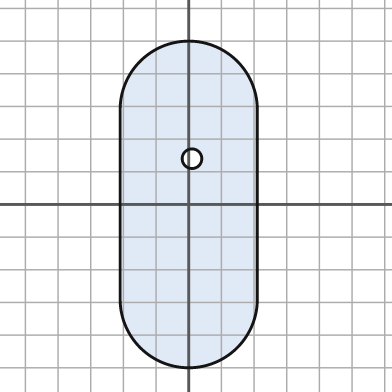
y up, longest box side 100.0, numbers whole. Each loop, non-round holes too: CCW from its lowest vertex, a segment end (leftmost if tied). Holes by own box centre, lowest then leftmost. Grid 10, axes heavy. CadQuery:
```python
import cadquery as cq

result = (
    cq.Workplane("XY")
    .moveTo(-21.0, -29.0)
    .threePointArc((0.0, -50.0), (21.0, -29.0))
    .lineTo(21.0, 29.0)
    .threePointArc((0.0, 50.0), (-21.0, 29.0))
    .close()
    .moveTo(1.0, 14.0)
    .circle(3.0)
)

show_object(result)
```